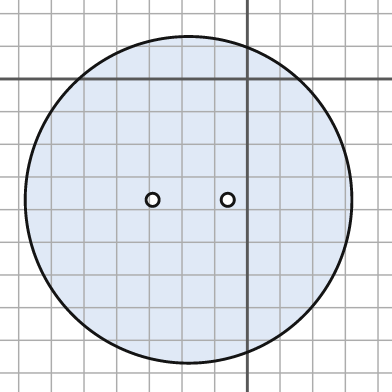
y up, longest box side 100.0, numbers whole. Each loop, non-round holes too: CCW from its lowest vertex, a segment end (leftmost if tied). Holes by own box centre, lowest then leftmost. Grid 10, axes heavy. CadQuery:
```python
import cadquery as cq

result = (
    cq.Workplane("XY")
    .moveTo(-18.0, -37.0)
    .circle(50.0)
    .moveTo(-29.0, -37.0)
    .circle(2.0)
    .moveTo(-6.0, -37.0)
    .circle(2.0)
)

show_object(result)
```